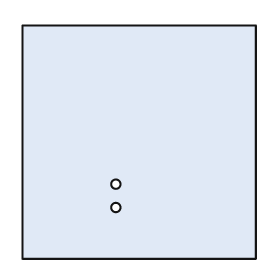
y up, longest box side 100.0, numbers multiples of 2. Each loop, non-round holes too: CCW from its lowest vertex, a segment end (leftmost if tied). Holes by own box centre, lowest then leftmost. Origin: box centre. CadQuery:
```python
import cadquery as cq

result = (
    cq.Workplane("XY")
    .moveTo(-50.0, -50.0)
    .lineTo(50.0, -50.0)
    .lineTo(50.0, 50.0)
    .lineTo(-50.0, 50.0)
    .close()
    .moveTo(-10.0, -28.0)
    .circle(2.0)
    .moveTo(-10.0, -18.0)
    .circle(2.0)
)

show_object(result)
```